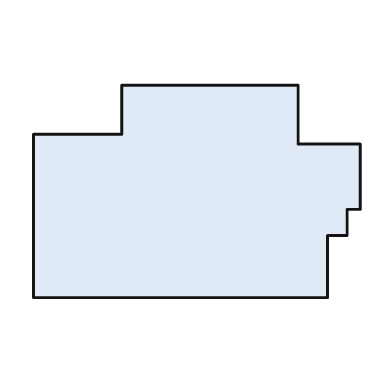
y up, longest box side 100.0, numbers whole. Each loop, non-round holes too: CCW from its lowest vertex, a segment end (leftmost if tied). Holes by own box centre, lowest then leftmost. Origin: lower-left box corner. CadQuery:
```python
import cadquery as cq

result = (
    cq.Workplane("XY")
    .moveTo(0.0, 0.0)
    .lineTo(90.0, 0.0)
    .lineTo(90.0, 19.0)
    .lineTo(96.0, 19.0)
    .lineTo(96.0, 27.0)
    .lineTo(100.0, 27.0)
    .lineTo(100.0, 47.0)
    .lineTo(81.0, 47.0)
    .lineTo(81.0, 65.0)
    .lineTo(27.0, 65.0)
    .lineTo(27.0, 50.0)
    .lineTo(0.0, 50.0)
    .close()
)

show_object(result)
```